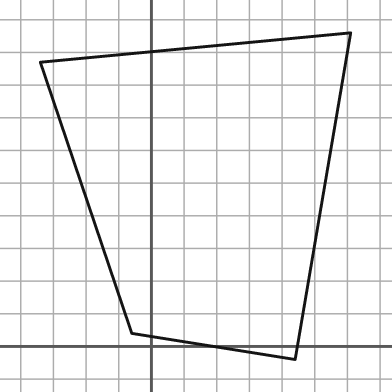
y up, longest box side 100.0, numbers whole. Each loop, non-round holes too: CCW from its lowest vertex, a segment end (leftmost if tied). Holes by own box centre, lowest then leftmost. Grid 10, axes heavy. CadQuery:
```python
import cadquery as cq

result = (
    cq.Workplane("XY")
    .moveTo(44.0, -4.0)
    .lineTo(61.0, 96.0)
    .lineTo(-34.0, 87.0)
    .lineTo(-6.0, 4.0)
    .close()
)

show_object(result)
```